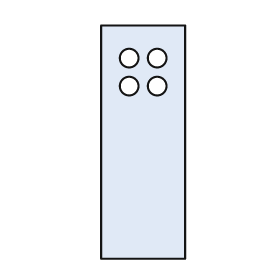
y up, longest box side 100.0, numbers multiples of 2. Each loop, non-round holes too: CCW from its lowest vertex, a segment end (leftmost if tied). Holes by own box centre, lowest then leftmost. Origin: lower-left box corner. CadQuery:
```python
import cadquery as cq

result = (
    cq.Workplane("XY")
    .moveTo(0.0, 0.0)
    .lineTo(36.0, 0.0)
    .lineTo(36.0, 100.0)
    .lineTo(0.0, 100.0)
    .close()
    .moveTo(12.0, 74.0)
    .circle(4.0)
    .moveTo(24.0, 74.0)
    .circle(4.0)
    .moveTo(12.0, 86.0)
    .circle(4.0)
    .moveTo(24.0, 86.0)
    .circle(4.0)
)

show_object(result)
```